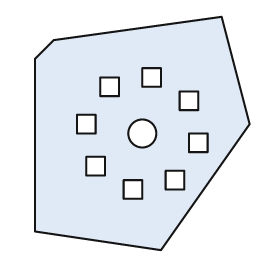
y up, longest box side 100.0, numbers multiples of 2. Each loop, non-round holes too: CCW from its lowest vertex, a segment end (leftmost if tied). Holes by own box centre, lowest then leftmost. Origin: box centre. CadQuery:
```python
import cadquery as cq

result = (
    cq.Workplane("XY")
    .moveTo(8.0, -50.0)
    .lineTo(46.0, 4.0)
    .lineTo(34.0, 50.0)
    .lineTo(-38.0, 40.0)
    .lineTo(-46.0, 32.0)
    .lineTo(-46.0, -42.0)
    .close()
    .moveTo(-8.0, -28.0)
    .lineTo(0.0, -28.0)
    .lineTo(0.0, -20.0)
    .lineTo(-8.0, -20.0)
    .close()
    .moveTo(10.0, -24.0)
    .lineTo(18.0, -24.0)
    .lineTo(18.0, -16.0)
    .lineTo(10.0, -16.0)
    .close()
    .moveTo(-24.0, -18.0)
    .lineTo(-16.0, -18.0)
    .lineTo(-16.0, -10.0)
    .lineTo(-24.0, -10.0)
    .close()
    .moveTo(20.0, -8.0)
    .lineTo(28.0, -8.0)
    .lineTo(28.0, 0.0)
    .lineTo(20.0, 0.0)
    .close()
    .moveTo(0.0, 0.0)
    .circle(6.0)
    .moveTo(-28.0, 0.0)
    .lineTo(-20.0, 0.0)
    .lineTo(-20.0, 8.0)
    .lineTo(-28.0, 8.0)
    .close()
    .moveTo(16.0, 10.0)
    .lineTo(24.0, 10.0)
    .lineTo(24.0, 18.0)
    .lineTo(16.0, 18.0)
    .close()
    .moveTo(-18.0, 16.0)
    .lineTo(-10.0, 16.0)
    .lineTo(-10.0, 24.0)
    .lineTo(-18.0, 24.0)
    .close()
    .moveTo(0.0, 20.0)
    .lineTo(8.0, 20.0)
    .lineTo(8.0, 28.0)
    .lineTo(0.0, 28.0)
    .close()
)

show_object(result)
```